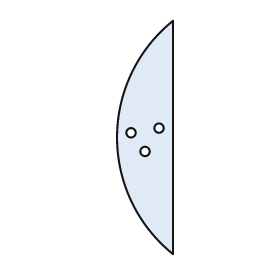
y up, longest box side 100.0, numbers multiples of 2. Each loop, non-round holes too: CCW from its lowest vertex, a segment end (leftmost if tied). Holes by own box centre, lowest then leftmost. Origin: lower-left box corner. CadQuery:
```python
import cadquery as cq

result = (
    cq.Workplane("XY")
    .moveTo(24.0, 0.0)
    .lineTo(24.0, 100.0)
    .threePointArc((0.0, 50.0), (24.0, 0.0))
    .close()
    .moveTo(12.0, 44.0)
    .circle(2.0)
    .moveTo(6.0, 52.0)
    .circle(2.0)
    .moveTo(18.0, 54.0)
    .circle(2.0)
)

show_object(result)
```